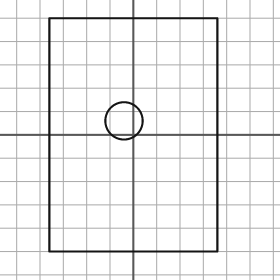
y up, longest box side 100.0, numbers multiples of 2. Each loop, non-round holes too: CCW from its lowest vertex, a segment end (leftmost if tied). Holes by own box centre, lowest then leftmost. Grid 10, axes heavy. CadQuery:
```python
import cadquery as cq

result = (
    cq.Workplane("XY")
    .moveTo(-36.0, -50.0)
    .lineTo(36.0, -50.0)
    .lineTo(36.0, 50.0)
    .lineTo(-36.0, 50.0)
    .close()
    .moveTo(-4.0, 6.0)
    .circle(8.0)
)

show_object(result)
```